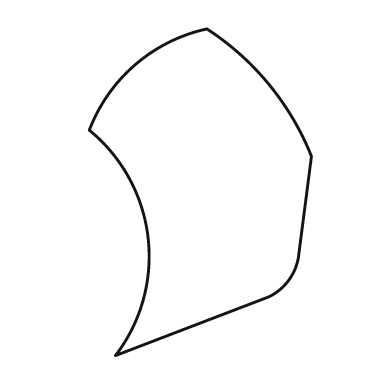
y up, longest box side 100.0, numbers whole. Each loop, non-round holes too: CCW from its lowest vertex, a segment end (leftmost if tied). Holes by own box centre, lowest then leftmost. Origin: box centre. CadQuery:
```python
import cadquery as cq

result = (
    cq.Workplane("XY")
    .moveTo(-26.0, -50.0)
    .lineTo(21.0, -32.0)
    .threePointArc((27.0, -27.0), (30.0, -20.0))
    .lineTo(34.0, 11.0)
    .threePointArc((21.0, 33.0), (2.0, 50.0))
    .threePointArc((-20.0, 39.0), (-34.0, 19.0))
    .threePointArc((-16.0, -14.0), (-26.0, -50.0))
    .close()
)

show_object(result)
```